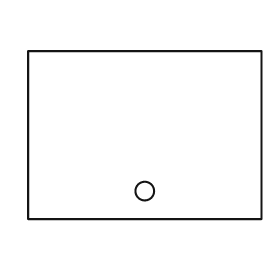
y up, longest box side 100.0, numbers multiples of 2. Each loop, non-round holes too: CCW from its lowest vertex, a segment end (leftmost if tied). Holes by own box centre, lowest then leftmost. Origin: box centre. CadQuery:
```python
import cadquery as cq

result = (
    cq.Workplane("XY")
    .moveTo(-50.0, -36.0)
    .lineTo(50.0, -36.0)
    .lineTo(50.0, 36.0)
    .lineTo(-50.0, 36.0)
    .close()
    .moveTo(0.0, -24.0)
    .circle(4.0)
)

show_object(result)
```